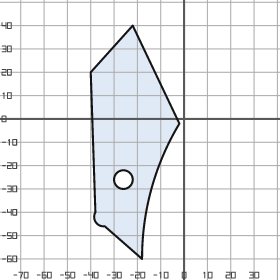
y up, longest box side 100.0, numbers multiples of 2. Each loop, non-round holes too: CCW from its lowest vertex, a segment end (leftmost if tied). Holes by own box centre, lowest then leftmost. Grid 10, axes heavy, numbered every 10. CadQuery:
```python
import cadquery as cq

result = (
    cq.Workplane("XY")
    .moveTo(-18.0, -60.0)
    .threePointArc((-14.0, -30.0), (-2.0, -2.0))
    .lineTo(-22.0, 40.0)
    .lineTo(-40.0, 20.0)
    .lineTo(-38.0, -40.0)
    .threePointArc((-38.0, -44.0), (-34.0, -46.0))
    .close()
    .moveTo(-26.0, -26.0)
    .circle(4.0)
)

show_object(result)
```